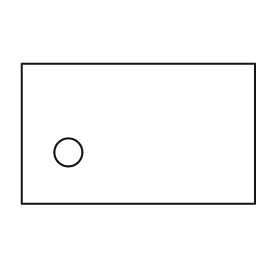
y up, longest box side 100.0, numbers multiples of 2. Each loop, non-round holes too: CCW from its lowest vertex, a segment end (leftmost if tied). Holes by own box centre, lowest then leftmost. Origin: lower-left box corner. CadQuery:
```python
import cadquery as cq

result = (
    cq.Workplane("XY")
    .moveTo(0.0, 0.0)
    .lineTo(100.0, 0.0)
    .lineTo(100.0, 60.0)
    .lineTo(0.0, 60.0)
    .close()
    .moveTo(20.0, 22.0)
    .circle(6.0)
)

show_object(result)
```